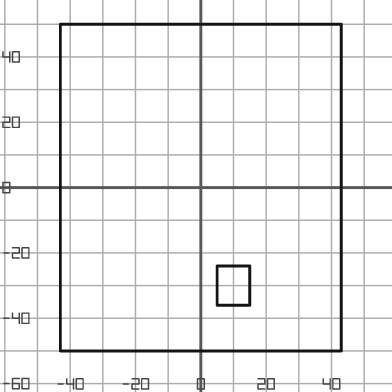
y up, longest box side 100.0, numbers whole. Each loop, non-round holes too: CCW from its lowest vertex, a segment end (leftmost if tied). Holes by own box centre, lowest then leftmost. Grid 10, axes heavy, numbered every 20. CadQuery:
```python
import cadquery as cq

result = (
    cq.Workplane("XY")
    .moveTo(-43.0, -50.0)
    .lineTo(43.0, -50.0)
    .lineTo(43.0, 50.0)
    .lineTo(-43.0, 50.0)
    .close()
    .moveTo(5.0, -36.0)
    .lineTo(15.0, -36.0)
    .lineTo(15.0, -24.0)
    .lineTo(5.0, -24.0)
    .close()
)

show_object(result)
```